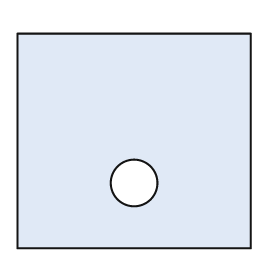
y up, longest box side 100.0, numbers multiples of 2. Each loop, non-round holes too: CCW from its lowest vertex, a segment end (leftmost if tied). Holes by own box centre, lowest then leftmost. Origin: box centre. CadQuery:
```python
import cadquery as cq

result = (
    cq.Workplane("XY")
    .moveTo(-50.0, -46.0)
    .lineTo(50.0, -46.0)
    .lineTo(50.0, 46.0)
    .lineTo(-50.0, 46.0)
    .close()
    .moveTo(0.0, -18.0)
    .circle(10.0)
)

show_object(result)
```